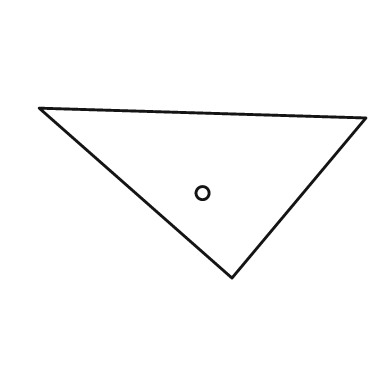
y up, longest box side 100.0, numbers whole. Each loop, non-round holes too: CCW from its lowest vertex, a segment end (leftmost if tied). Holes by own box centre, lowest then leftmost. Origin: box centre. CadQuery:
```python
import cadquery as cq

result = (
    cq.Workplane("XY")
    .moveTo(9.0, -26.0)
    .lineTo(50.0, 23.0)
    .lineTo(-50.0, 26.0)
    .close()
    .moveTo(0.0, 0.0)
    .circle(2.0)
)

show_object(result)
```